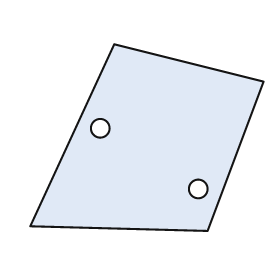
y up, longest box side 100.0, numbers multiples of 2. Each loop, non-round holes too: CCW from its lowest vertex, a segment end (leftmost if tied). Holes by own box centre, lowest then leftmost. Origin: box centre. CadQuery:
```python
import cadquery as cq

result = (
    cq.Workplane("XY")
    .moveTo(26.0, -40.0)
    .lineTo(50.0, 24.0)
    .lineTo(-14.0, 40.0)
    .lineTo(-50.0, -38.0)
    .close()
    .moveTo(22.0, -22.0)
    .circle(4.0)
    .moveTo(-20.0, 4.0)
    .circle(4.0)
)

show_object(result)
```